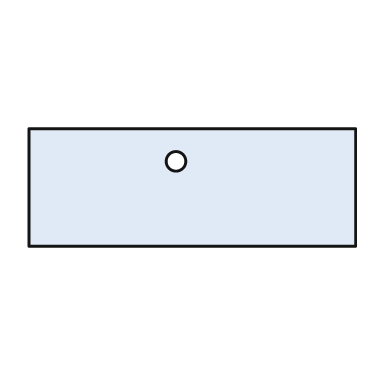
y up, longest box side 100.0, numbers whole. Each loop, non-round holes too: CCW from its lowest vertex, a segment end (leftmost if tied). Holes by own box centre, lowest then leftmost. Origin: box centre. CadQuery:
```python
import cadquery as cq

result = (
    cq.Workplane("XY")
    .moveTo(-50.0, -18.0)
    .lineTo(50.0, -18.0)
    .lineTo(50.0, 18.0)
    .lineTo(-50.0, 18.0)
    .close()
    .moveTo(-5.0, 8.0)
    .circle(3.0)
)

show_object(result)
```